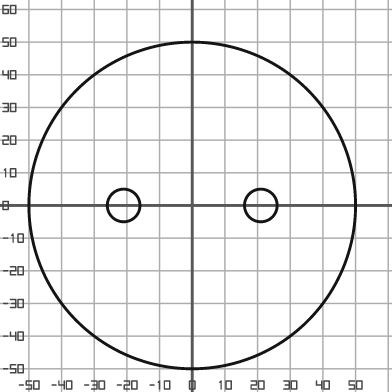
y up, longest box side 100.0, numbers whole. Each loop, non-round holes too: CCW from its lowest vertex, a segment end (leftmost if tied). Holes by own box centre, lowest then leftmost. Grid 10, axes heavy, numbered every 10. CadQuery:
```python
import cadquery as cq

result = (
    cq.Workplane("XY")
    .moveTo(0.0, 0.0)
    .circle(50.0)
    .moveTo(-21.0, 0.0)
    .circle(5.0)
    .moveTo(21.0, 0.0)
    .circle(5.0)
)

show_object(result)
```